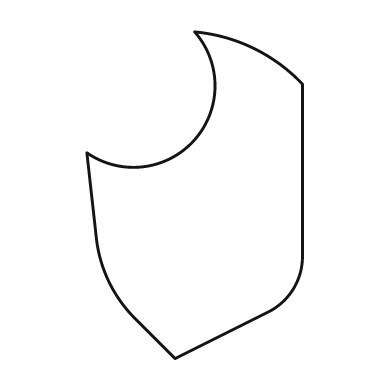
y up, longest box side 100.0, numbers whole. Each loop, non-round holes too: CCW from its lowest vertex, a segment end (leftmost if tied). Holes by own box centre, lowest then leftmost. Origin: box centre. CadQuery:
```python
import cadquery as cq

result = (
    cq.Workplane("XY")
    .moveTo(-6.0, -50.0)
    .lineTo(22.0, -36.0)
    .threePointArc((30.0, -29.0), (33.0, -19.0))
    .lineTo(33.0, 34.0)
    .threePointArc((18.0, 45.0), (0.0, 50.0))
    .threePointArc((0.0, 17.0), (-33.0, 13.0))
    .lineTo(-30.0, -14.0)
    .threePointArc((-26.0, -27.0), (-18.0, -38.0))
    .close()
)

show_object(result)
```